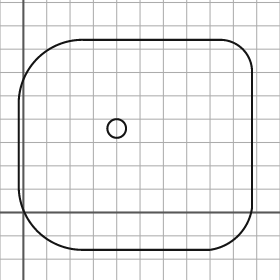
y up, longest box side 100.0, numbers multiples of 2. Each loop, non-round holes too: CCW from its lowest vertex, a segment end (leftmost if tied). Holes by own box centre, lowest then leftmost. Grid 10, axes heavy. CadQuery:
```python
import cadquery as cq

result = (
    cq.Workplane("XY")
    .moveTo(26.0, -16.0)
    .lineTo(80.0, -16.0)
    .threePointArc((92.0, -10.0), (98.0, 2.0))
    .lineTo(98.0, 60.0)
    .threePointArc((94.0, 70.0), (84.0, 74.0))
    .lineTo(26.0, 74.0)
    .threePointArc((6.0, 66.0), (-2.0, 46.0))
    .lineTo(-2.0, 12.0)
    .threePointArc((6.0, -8.0), (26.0, -16.0))
    .close()
    .moveTo(40.0, 36.0)
    .circle(4.0)
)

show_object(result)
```